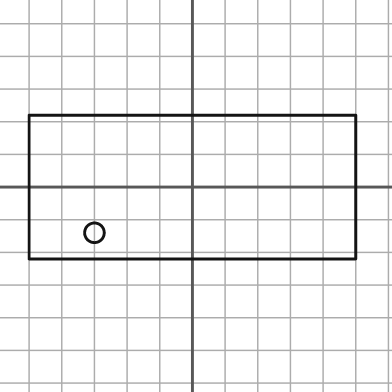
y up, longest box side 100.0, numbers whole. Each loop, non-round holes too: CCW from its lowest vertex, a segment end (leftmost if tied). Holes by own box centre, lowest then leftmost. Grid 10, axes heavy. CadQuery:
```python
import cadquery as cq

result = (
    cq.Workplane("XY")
    .moveTo(-50.0, -22.0)
    .lineTo(50.0, -22.0)
    .lineTo(50.0, 22.0)
    .lineTo(-50.0, 22.0)
    .close()
    .moveTo(-30.0, -14.0)
    .circle(3.0)
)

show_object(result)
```